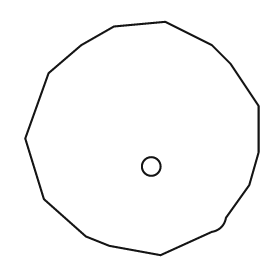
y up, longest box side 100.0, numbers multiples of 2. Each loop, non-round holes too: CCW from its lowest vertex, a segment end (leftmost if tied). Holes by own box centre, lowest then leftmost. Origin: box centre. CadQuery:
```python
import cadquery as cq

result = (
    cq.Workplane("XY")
    .moveTo(8.0, -50.0)
    .lineTo(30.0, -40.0)
    .threePointArc((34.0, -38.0), (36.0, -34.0))
    .lineTo(46.0, -20.0)
    .lineTo(50.0, -6.0)
    .lineTo(50.0, 14.0)
    .lineTo(38.0, 32.0)
    .lineTo(30.0, 40.0)
    .lineTo(10.0, 50.0)
    .lineTo(-12.0, 48.0)
    .lineTo(-26.0, 40.0)
    .lineTo(-40.0, 28.0)
    .lineTo(-50.0, 0.0)
    .lineTo(-42.0, -26.0)
    .lineTo(-24.0, -42.0)
    .lineTo(-14.0, -46.0)
    .close()
    .moveTo(4.0, -12.0)
    .circle(4.0)
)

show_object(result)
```